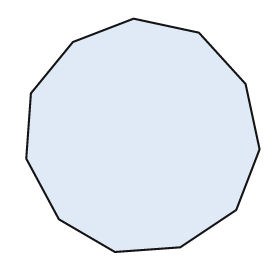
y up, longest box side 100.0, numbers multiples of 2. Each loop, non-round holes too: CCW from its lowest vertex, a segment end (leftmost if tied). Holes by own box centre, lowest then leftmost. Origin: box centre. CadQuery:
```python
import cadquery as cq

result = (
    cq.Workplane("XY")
    .moveTo(-12.0, -50.0)
    .lineTo(16.0, -48.0)
    .lineTo(40.0, -32.0)
    .lineTo(50.0, -6.0)
    .lineTo(44.0, 22.0)
    .lineTo(24.0, 44.0)
    .lineTo(-4.0, 50.0)
    .lineTo(-30.0, 40.0)
    .lineTo(-48.0, 18.0)
    .lineTo(-50.0, -10.0)
    .lineTo(-36.0, -36.0)
    .close()
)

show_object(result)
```